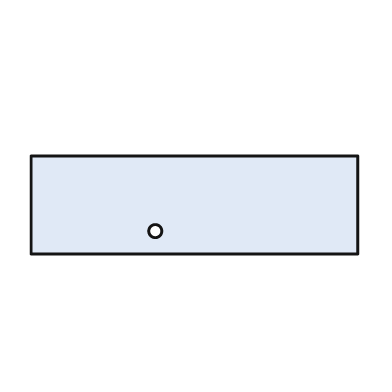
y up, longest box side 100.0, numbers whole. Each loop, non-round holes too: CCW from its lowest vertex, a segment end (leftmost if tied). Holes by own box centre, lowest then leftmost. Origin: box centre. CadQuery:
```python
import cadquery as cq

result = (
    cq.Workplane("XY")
    .moveTo(-50.0, -15.0)
    .lineTo(50.0, -15.0)
    .lineTo(50.0, 15.0)
    .lineTo(-50.0, 15.0)
    .close()
    .moveTo(-12.0, -8.0)
    .circle(2.0)
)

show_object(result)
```